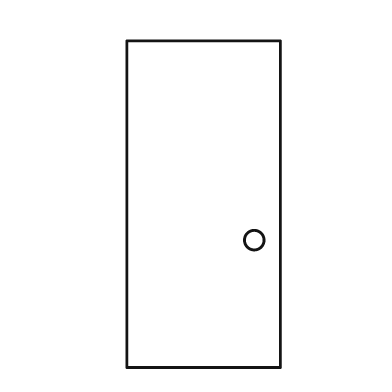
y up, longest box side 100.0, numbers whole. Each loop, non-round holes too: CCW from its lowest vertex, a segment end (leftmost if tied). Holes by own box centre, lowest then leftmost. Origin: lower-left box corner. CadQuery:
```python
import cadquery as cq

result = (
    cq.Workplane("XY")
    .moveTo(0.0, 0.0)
    .lineTo(47.0, 0.0)
    .lineTo(47.0, 100.0)
    .lineTo(0.0, 100.0)
    .close()
    .moveTo(39.0, 39.0)
    .circle(3.0)
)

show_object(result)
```